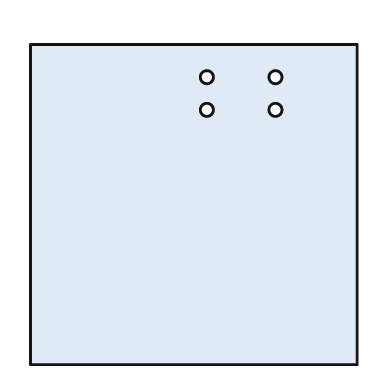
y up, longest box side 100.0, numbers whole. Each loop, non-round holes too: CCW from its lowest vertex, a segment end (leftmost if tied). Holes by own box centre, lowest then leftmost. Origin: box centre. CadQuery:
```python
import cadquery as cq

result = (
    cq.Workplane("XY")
    .moveTo(-50.0, -49.0)
    .lineTo(50.0, -49.0)
    .lineTo(50.0, 49.0)
    .lineTo(-50.0, 49.0)
    .close()
    .moveTo(4.0, 29.0)
    .circle(2.0)
    .moveTo(25.0, 29.0)
    .circle(2.0)
    .moveTo(4.0, 39.0)
    .circle(2.0)
    .moveTo(25.0, 39.0)
    .circle(2.0)
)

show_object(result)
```